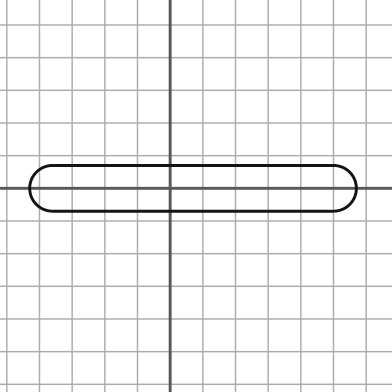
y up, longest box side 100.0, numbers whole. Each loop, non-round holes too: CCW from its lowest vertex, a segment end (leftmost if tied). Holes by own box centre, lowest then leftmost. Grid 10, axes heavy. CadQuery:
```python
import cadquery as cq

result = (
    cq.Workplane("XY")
    .moveTo(-36.0, -7.0)
    .lineTo(50.0, -7.0)
    .threePointArc((57.0, 0.0), (50.0, 7.0))
    .lineTo(-36.0, 7.0)
    .threePointArc((-43.0, 0.0), (-36.0, -7.0))
    .close()
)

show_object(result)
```